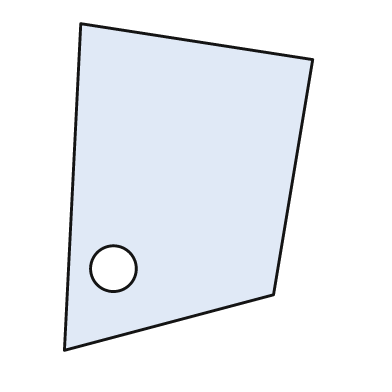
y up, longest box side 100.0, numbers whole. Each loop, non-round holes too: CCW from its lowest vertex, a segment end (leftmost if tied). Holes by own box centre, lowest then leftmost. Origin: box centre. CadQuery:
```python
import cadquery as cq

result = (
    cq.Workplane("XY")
    .moveTo(-38.0, -50.0)
    .lineTo(26.0, -33.0)
    .lineTo(38.0, 39.0)
    .lineTo(-33.0, 50.0)
    .close()
    .moveTo(-23.0, -25.0)
    .circle(7.0)
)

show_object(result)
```